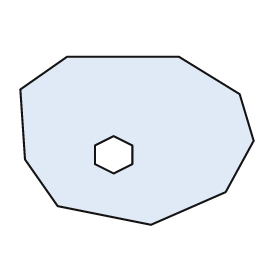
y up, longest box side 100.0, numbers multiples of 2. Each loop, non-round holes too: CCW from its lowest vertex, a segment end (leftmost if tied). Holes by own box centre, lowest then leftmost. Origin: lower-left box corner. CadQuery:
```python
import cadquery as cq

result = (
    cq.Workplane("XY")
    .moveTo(56.0, 0.0)
    .lineTo(88.0, 14.0)
    .lineTo(100.0, 36.0)
    .lineTo(94.0, 56.0)
    .lineTo(68.0, 72.0)
    .lineTo(20.0, 72.0)
    .lineTo(0.0, 58.0)
    .lineTo(2.0, 28.0)
    .lineTo(16.0, 8.0)
    .close()
    .moveTo(40.0, 22.0)
    .lineTo(48.0, 26.0)
    .lineTo(48.0, 34.0)
    .lineTo(40.0, 38.0)
    .lineTo(32.0, 34.0)
    .lineTo(32.0, 26.0)
    .close()
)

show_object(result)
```